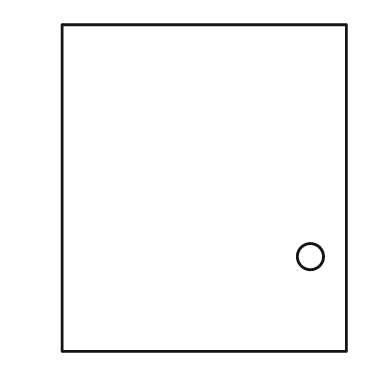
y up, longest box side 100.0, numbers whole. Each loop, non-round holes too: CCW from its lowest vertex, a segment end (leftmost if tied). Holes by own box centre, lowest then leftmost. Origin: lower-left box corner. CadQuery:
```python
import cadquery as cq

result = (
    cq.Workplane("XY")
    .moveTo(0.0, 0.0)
    .lineTo(87.0, 0.0)
    .lineTo(87.0, 100.0)
    .lineTo(0.0, 100.0)
    .close()
    .moveTo(76.0, 29.0)
    .circle(4.0)
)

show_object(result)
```